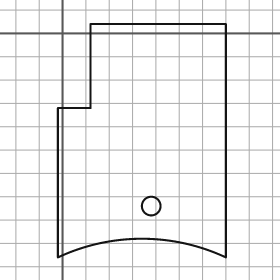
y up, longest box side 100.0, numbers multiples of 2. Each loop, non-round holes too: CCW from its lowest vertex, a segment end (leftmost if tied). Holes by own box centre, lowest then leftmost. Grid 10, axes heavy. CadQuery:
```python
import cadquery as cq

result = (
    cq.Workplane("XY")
    .moveTo(-2.0, -96.0)
    .threePointArc((34.0, -88.0), (70.0, -96.0))
    .lineTo(70.0, 4.0)
    .lineTo(12.0, 4.0)
    .lineTo(12.0, -32.0)
    .lineTo(-2.0, -32.0)
    .close()
    .moveTo(38.0, -74.0)
    .circle(4.0)
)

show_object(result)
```